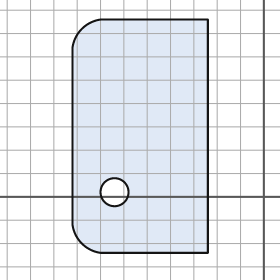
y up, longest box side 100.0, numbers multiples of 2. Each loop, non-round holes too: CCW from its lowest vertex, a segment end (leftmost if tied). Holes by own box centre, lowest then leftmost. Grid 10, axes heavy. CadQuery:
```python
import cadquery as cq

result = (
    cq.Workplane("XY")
    .moveTo(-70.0, -24.0)
    .lineTo(-24.0, -24.0)
    .lineTo(-24.0, 76.0)
    .lineTo(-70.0, 76.0)
    .threePointArc((-78.0, 72.0), (-82.0, 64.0))
    .lineTo(-82.0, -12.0)
    .threePointArc((-78.0, -20.0), (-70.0, -24.0))
    .close()
    .moveTo(-64.0, 2.0)
    .circle(6.0)
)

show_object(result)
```